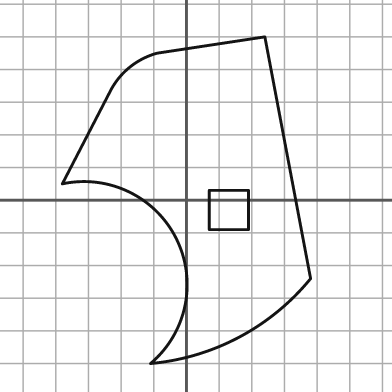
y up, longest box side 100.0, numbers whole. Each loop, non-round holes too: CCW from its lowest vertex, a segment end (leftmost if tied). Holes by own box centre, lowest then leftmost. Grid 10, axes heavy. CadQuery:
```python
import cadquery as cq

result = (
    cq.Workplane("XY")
    .moveTo(-11.0, -50.0)
    .threePointArc((16.0, -42.0), (38.0, -24.0))
    .lineTo(24.0, 50.0)
    .lineTo(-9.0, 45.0)
    .threePointArc((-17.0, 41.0), (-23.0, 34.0))
    .lineTo(-38.0, 5.0)
    .threePointArc((-3.0, -12.0), (-11.0, -50.0))
    .close()
    .moveTo(7.0, -9.0)
    .lineTo(19.0, -9.0)
    .lineTo(19.0, 3.0)
    .lineTo(7.0, 3.0)
    .close()
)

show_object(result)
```